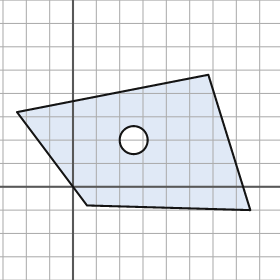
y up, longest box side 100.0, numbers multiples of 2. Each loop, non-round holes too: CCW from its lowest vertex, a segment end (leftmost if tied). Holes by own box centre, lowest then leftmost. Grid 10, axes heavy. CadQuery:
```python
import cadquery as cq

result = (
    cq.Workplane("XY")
    .moveTo(76.0, -10.0)
    .lineTo(58.0, 48.0)
    .lineTo(-24.0, 32.0)
    .lineTo(6.0, -8.0)
    .close()
    .moveTo(26.0, 20.0)
    .circle(6.0)
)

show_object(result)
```